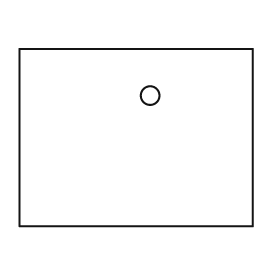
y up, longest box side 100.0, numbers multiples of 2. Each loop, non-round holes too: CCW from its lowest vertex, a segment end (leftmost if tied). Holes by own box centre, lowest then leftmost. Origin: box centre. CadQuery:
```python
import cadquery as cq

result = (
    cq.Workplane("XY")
    .moveTo(-50.0, -38.0)
    .lineTo(50.0, -38.0)
    .lineTo(50.0, 38.0)
    .lineTo(-50.0, 38.0)
    .close()
    .moveTo(6.0, 18.0)
    .circle(4.0)
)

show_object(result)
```